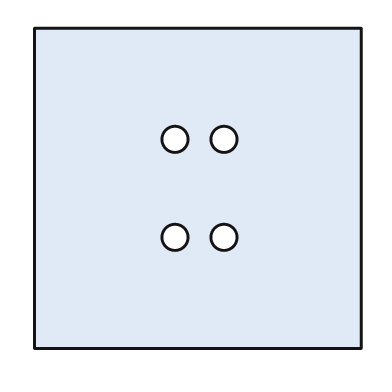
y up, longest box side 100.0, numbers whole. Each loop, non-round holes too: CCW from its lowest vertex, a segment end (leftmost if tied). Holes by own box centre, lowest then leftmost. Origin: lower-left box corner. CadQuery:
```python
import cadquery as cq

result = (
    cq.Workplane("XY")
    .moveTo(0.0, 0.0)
    .lineTo(100.0, 0.0)
    .lineTo(100.0, 98.0)
    .lineTo(0.0, 98.0)
    .close()
    .moveTo(43.0, 34.0)
    .circle(4.0)
    .moveTo(58.0, 34.0)
    .circle(4.0)
    .moveTo(43.0, 64.0)
    .circle(4.0)
    .moveTo(58.0, 64.0)
    .circle(4.0)
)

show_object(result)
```